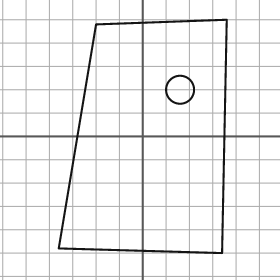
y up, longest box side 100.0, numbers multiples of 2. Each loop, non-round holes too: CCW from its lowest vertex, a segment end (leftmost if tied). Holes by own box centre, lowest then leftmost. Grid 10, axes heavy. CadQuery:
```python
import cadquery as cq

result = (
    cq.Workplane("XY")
    .moveTo(34.0, -50.0)
    .lineTo(36.0, 50.0)
    .lineTo(-20.0, 48.0)
    .lineTo(-36.0, -48.0)
    .close()
    .moveTo(16.0, 20.0)
    .circle(6.0)
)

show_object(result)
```